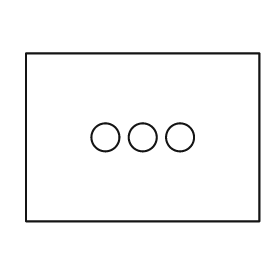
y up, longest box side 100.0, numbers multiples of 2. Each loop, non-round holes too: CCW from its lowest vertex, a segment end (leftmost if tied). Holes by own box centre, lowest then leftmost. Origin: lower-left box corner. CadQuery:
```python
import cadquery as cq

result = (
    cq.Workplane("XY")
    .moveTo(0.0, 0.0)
    .lineTo(100.0, 0.0)
    .lineTo(100.0, 72.0)
    .lineTo(0.0, 72.0)
    .close()
    .moveTo(34.0, 36.0)
    .circle(6.0)
    .moveTo(50.0, 36.0)
    .circle(6.0)
    .moveTo(66.0, 36.0)
    .circle(6.0)
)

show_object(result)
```